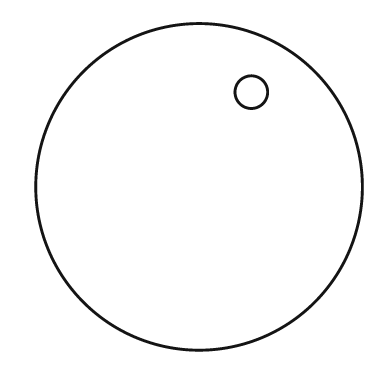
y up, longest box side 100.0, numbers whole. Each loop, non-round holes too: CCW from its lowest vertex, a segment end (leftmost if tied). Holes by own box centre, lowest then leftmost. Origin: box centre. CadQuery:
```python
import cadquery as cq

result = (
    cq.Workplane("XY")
    .moveTo(0.0, 0.0)
    .circle(50.0)
    .moveTo(16.0, 29.0)
    .circle(5.0)
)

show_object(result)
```